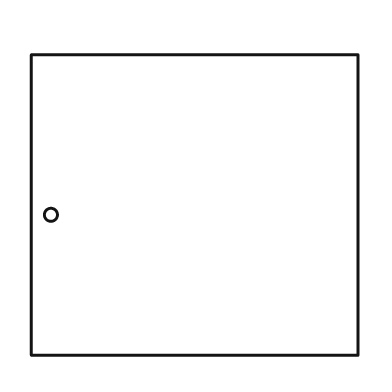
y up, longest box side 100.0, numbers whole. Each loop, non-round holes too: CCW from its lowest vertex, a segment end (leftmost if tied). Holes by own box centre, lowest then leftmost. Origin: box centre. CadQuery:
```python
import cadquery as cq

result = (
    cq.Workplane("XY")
    .moveTo(-50.0, -46.0)
    .lineTo(50.0, -46.0)
    .lineTo(50.0, 46.0)
    .lineTo(-50.0, 46.0)
    .close()
    .moveTo(-44.0, -3.0)
    .circle(2.0)
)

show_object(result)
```